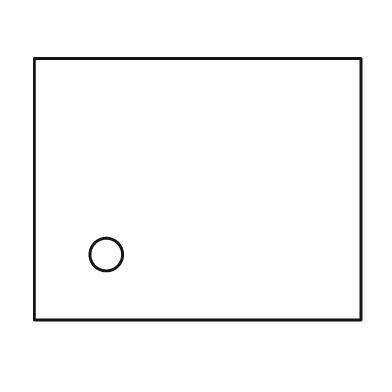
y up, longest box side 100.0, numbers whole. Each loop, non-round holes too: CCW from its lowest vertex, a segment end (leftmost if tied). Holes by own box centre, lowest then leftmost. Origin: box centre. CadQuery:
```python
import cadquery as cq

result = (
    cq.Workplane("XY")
    .moveTo(-50.0, -40.0)
    .lineTo(50.0, -40.0)
    .lineTo(50.0, 40.0)
    .lineTo(-50.0, 40.0)
    .close()
    .moveTo(-28.0, -20.0)
    .circle(5.0)
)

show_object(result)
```